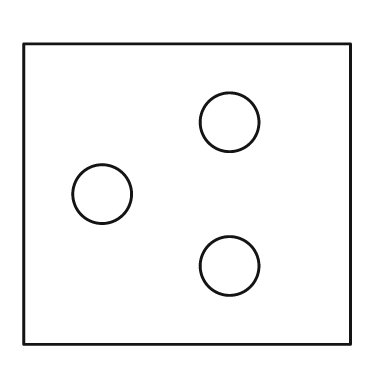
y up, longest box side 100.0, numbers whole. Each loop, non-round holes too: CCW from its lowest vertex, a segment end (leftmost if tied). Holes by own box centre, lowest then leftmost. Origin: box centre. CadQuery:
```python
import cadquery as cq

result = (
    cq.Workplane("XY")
    .moveTo(-50.0, -46.0)
    .lineTo(50.0, -46.0)
    .lineTo(50.0, 46.0)
    .lineTo(-50.0, 46.0)
    .close()
    .moveTo(13.0, -22.0)
    .circle(9.0)
    .moveTo(-26.0, 0.0)
    .circle(9.0)
    .moveTo(13.0, 22.0)
    .circle(9.0)
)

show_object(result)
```